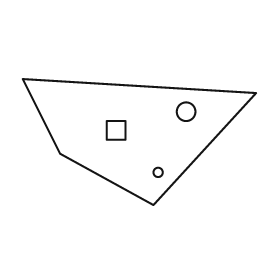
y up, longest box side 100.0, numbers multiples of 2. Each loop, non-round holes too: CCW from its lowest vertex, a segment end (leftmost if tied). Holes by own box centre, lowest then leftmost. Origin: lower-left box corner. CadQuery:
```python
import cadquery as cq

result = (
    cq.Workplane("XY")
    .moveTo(56.0, 0.0)
    .lineTo(100.0, 48.0)
    .lineTo(0.0, 54.0)
    .lineTo(16.0, 22.0)
    .close()
    .moveTo(58.0, 14.0)
    .circle(2.0)
    .moveTo(36.0, 28.0)
    .lineTo(44.0, 28.0)
    .lineTo(44.0, 36.0)
    .lineTo(36.0, 36.0)
    .close()
    .moveTo(70.0, 40.0)
    .circle(4.0)
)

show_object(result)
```